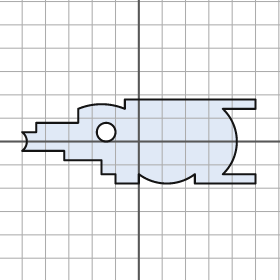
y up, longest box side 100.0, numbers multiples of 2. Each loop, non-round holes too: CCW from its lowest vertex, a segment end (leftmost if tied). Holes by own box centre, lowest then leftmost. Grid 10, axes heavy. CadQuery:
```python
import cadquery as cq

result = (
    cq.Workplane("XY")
    .moveTo(-10.0, -18.0)
    .lineTo(0.0, -18.0)
    .lineTo(0.0, -14.0)
    .threePointArc((12.0, -18.0), (24.0, -14.0))
    .lineTo(24.0, -18.0)
    .lineTo(50.0, -18.0)
    .lineTo(50.0, -14.0)
    .lineTo(36.0, -14.0)
    .threePointArc((42.0, 0.0), (36.0, 14.0))
    .lineTo(50.0, 14.0)
    .lineTo(50.0, 18.0)
    .lineTo(-6.0, 18.0)
    .lineTo(-6.0, 14.0)
    .threePointArc((-16.0, 16.0), (-26.0, 14.0))
    .lineTo(-26.0, 8.0)
    .lineTo(-44.0, 8.0)
    .lineTo(-44.0, 4.0)
    .lineTo(-50.0, 4.0)
    .threePointArc((-48.0, 0.0), (-50.0, -4.0))
    .lineTo(-32.0, -4.0)
    .lineTo(-32.0, -8.0)
    .lineTo(-16.0, -8.0)
    .lineTo(-16.0, -14.0)
    .lineTo(-10.0, -14.0)
    .close()
    .moveTo(-14.0, 4.0)
    .circle(4.0)
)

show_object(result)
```